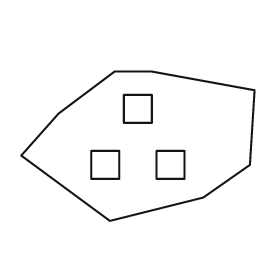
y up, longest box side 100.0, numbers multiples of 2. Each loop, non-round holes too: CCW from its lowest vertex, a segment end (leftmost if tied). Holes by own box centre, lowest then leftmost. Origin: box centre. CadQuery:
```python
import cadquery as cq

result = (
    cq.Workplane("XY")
    .moveTo(-12.0, -32.0)
    .lineTo(28.0, -22.0)
    .lineTo(48.0, -8.0)
    .lineTo(50.0, 24.0)
    .lineTo(6.0, 32.0)
    .lineTo(-10.0, 32.0)
    .lineTo(-34.0, 14.0)
    .lineTo(-50.0, -4.0)
    .close()
    .moveTo(-20.0, -14.0)
    .lineTo(-8.0, -14.0)
    .lineTo(-8.0, -2.0)
    .lineTo(-20.0, -2.0)
    .close()
    .moveTo(8.0, -14.0)
    .lineTo(20.0, -14.0)
    .lineTo(20.0, -2.0)
    .lineTo(8.0, -2.0)
    .close()
    .moveTo(-6.0, 10.0)
    .lineTo(6.0, 10.0)
    .lineTo(6.0, 22.0)
    .lineTo(-6.0, 22.0)
    .close()
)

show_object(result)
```